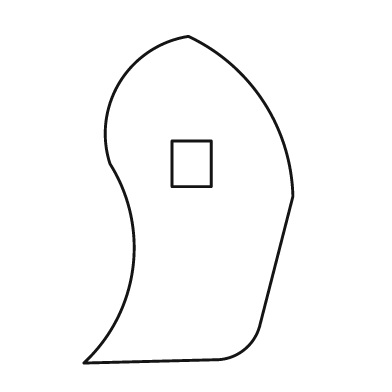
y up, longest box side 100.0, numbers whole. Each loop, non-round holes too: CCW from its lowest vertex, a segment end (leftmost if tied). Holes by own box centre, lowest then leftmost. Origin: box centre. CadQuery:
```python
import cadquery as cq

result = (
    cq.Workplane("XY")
    .moveTo(-32.0, -50.0)
    .lineTo(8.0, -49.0)
    .threePointArc((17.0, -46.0), (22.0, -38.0))
    .lineTo(32.0, 1.0)
    .threePointArc((23.0, 30.0), (0.0, 50.0))
    .threePointArc((-21.0, 36.0), (-24.0, 11.0))
    .threePointArc((-17.0, -21.0), (-32.0, -50.0))
    .close()
    .moveTo(-5.0, 4.0)
    .lineTo(7.0, 4.0)
    .lineTo(7.0, 18.0)
    .lineTo(-5.0, 18.0)
    .close()
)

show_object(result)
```